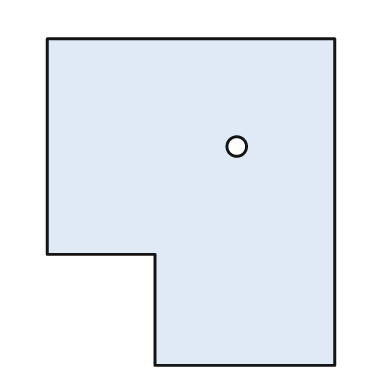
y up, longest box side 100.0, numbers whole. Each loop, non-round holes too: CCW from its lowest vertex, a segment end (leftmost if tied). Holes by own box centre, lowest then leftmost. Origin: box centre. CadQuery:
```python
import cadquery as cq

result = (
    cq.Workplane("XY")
    .moveTo(-11.0, -50.0)
    .lineTo(44.0, -50.0)
    .lineTo(44.0, 50.0)
    .lineTo(-44.0, 50.0)
    .lineTo(-44.0, -16.0)
    .lineTo(-11.0, -16.0)
    .close()
    .moveTo(14.0, 17.0)
    .circle(3.0)
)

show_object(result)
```